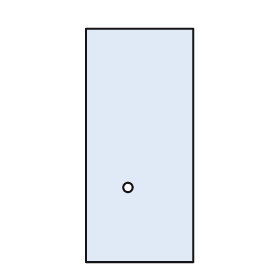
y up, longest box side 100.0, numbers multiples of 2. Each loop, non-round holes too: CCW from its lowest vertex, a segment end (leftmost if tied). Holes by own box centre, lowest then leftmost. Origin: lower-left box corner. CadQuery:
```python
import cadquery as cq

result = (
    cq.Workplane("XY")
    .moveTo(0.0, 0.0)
    .lineTo(46.0, 0.0)
    .lineTo(46.0, 100.0)
    .lineTo(0.0, 100.0)
    .close()
    .moveTo(18.0, 32.0)
    .circle(2.0)
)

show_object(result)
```